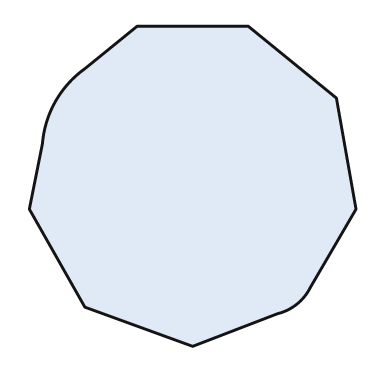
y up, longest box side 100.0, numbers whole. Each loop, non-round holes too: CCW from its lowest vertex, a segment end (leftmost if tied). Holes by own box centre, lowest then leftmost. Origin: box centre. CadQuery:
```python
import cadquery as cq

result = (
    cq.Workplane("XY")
    .moveTo(0.0, -49.0)
    .lineTo(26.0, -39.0)
    .threePointArc((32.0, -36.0), (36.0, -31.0))
    .lineTo(50.0, -7.0)
    .lineTo(44.0, 27.0)
    .lineTo(17.0, 49.0)
    .lineTo(-17.0, 49.0)
    .lineTo(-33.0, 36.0)
    .threePointArc((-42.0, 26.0), (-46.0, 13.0))
    .lineTo(-50.0, -7.0)
    .lineTo(-33.0, -37.0)
    .close()
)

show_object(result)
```